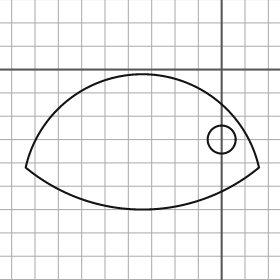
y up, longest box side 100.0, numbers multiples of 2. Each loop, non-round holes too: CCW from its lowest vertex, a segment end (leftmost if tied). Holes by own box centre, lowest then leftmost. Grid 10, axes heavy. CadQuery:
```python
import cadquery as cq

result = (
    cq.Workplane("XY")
    .moveTo(-84.0, -42.0)
    .threePointArc((-34.0, -60.0), (16.0, -42.0))
    .threePointArc((-34.0, -2.0), (-84.0, -42.0))
    .close()
    .moveTo(0.0, -30.0)
    .circle(6.0)
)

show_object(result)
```